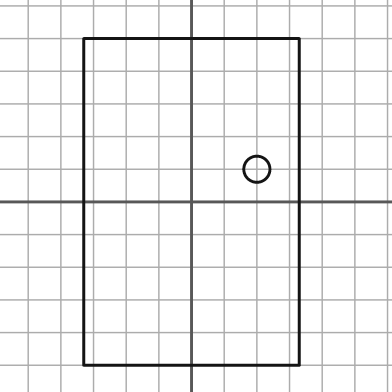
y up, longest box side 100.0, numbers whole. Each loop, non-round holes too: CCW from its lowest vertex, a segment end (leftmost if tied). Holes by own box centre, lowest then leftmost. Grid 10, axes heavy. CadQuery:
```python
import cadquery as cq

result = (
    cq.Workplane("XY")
    .moveTo(-33.0, -50.0)
    .lineTo(33.0, -50.0)
    .lineTo(33.0, 50.0)
    .lineTo(-33.0, 50.0)
    .close()
    .moveTo(20.0, 10.0)
    .circle(4.0)
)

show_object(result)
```